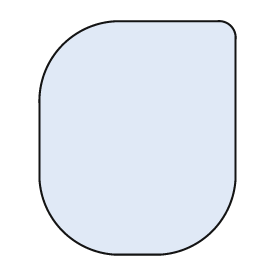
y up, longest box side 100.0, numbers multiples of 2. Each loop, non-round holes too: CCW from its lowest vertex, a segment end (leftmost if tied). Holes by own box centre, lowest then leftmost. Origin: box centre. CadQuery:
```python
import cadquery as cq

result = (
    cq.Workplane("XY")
    .moveTo(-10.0, -50.0)
    .lineTo(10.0, -50.0)
    .threePointArc((32.0, -40.0), (42.0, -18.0))
    .lineTo(42.0, 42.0)
    .threePointArc((40.0, 48.0), (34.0, 50.0))
    .lineTo(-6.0, 50.0)
    .threePointArc((-32.0, 40.0), (-42.0, 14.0))
    .lineTo(-42.0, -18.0)
    .threePointArc((-32.0, -40.0), (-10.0, -50.0))
    .close()
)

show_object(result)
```